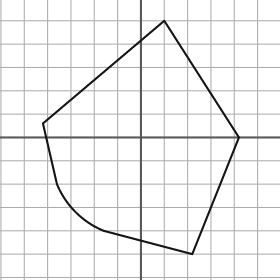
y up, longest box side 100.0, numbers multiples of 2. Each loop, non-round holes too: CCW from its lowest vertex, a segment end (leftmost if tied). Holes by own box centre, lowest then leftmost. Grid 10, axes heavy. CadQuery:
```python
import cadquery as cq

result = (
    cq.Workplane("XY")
    .moveTo(22.0, -50.0)
    .lineTo(42.0, 0.0)
    .lineTo(10.0, 50.0)
    .lineTo(-42.0, 6.0)
    .lineTo(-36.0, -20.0)
    .threePointArc((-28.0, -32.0), (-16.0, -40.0))
    .close()
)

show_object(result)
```